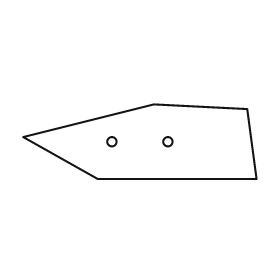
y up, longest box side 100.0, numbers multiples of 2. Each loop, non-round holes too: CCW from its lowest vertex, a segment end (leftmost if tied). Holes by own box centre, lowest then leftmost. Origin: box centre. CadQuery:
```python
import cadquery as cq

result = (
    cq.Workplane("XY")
    .moveTo(-18.0, -16.0)
    .lineTo(50.0, -16.0)
    .lineTo(46.0, 14.0)
    .lineTo(6.0, 16.0)
    .lineTo(-50.0, 2.0)
    .close()
    .moveTo(-12.0, 0.0)
    .circle(2.0)
    .moveTo(12.0, 0.0)
    .circle(2.0)
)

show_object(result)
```